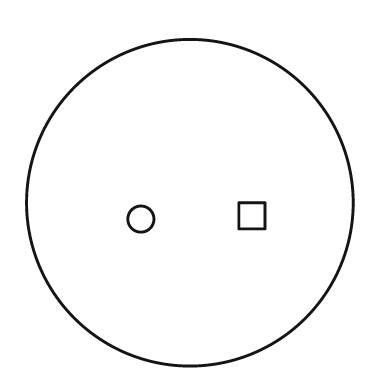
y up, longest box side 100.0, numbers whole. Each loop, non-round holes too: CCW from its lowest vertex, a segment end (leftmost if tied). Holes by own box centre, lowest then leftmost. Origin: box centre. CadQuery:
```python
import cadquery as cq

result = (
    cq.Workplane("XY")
    .moveTo(0.0, 0.0)
    .circle(50.0)
    .moveTo(-15.0, -5.0)
    .circle(4.0)
    .moveTo(15.0, -8.0)
    .lineTo(23.0, -8.0)
    .lineTo(23.0, 0.0)
    .lineTo(15.0, 0.0)
    .close()
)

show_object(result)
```